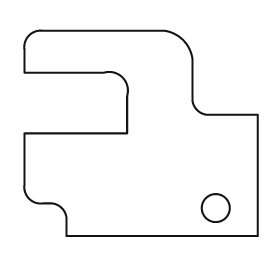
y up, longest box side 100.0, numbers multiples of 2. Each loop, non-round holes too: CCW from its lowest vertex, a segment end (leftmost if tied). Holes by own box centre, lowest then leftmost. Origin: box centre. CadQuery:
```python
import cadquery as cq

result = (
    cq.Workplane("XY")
    .moveTo(-32.0, -44.0)
    .lineTo(50.0, -44.0)
    .lineTo(50.0, 8.0)
    .lineTo(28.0, 8.0)
    .threePointArc((24.0, 10.0), (22.0, 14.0))
    .lineTo(22.0, 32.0)
    .threePointArc((18.0, 40.0), (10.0, 44.0))
    .lineTo(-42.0, 44.0)
    .threePointArc((-48.0, 42.0), (-50.0, 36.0))
    .lineTo(-50.0, 26.0)
    .lineTo(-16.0, 26.0)
    .threePointArc((-8.0, 24.0), (-6.0, 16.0))
    .lineTo(-6.0, 0.0)
    .lineTo(-50.0, 0.0)
    .lineTo(-50.0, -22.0)
    .threePointArc((-48.0, -28.0), (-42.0, -30.0))
    .lineTo(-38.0, -30.0)
    .threePointArc((-34.0, -32.0), (-32.0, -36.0))
    .close()
    .moveTo(32.0, -32.0)
    .circle(6.0)
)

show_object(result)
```